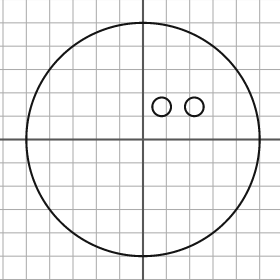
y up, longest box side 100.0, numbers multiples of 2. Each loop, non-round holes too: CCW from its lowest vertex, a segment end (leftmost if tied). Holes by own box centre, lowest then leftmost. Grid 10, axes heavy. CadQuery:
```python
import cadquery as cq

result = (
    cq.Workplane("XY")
    .moveTo(0.0, 0.0)
    .circle(50.0)
    .moveTo(8.0, 14.0)
    .circle(4.0)
    .moveTo(22.0, 14.0)
    .circle(4.0)
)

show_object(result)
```